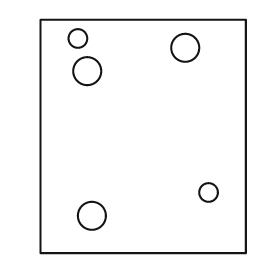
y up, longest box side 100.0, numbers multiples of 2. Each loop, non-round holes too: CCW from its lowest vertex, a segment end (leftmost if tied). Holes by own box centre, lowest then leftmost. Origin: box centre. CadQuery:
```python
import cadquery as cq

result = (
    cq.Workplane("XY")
    .moveTo(-44.0, -50.0)
    .lineTo(44.0, -50.0)
    .lineTo(44.0, 50.0)
    .lineTo(-44.0, 50.0)
    .close()
    .moveTo(-22.0, -34.0)
    .circle(6.0)
    .moveTo(28.0, -24.0)
    .circle(4.0)
    .moveTo(-24.0, 28.0)
    .circle(6.0)
    .moveTo(18.0, 38.0)
    .circle(6.0)
    .moveTo(-28.0, 42.0)
    .circle(4.0)
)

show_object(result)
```